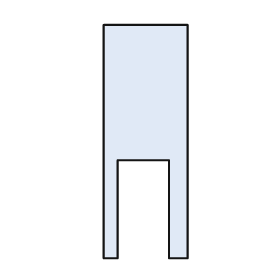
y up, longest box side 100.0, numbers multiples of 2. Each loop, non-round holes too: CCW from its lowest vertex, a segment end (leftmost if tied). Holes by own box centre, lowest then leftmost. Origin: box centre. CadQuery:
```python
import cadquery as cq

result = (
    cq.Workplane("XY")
    .moveTo(-18.0, -50.0)
    .lineTo(-12.0, -50.0)
    .lineTo(-12.0, -8.0)
    .lineTo(10.0, -8.0)
    .lineTo(10.0, -50.0)
    .lineTo(18.0, -50.0)
    .lineTo(18.0, 50.0)
    .lineTo(-18.0, 50.0)
    .close()
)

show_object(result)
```